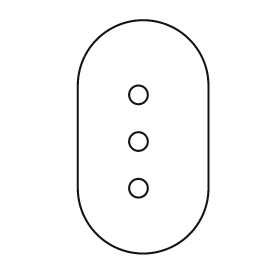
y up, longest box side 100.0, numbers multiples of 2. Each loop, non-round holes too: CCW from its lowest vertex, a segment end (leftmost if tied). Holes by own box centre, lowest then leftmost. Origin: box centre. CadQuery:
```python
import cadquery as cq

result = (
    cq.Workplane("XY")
    .moveTo(-28.0, -22.0)
    .threePointArc((0.0, -50.0), (28.0, -22.0))
    .lineTo(28.0, 22.0)
    .threePointArc((0.0, 50.0), (-28.0, 22.0))
    .close()
    .moveTo(-2.0, -22.0)
    .circle(4.0)
    .moveTo(-2.0, -2.0)
    .circle(4.0)
    .moveTo(-2.0, 18.0)
    .circle(4.0)
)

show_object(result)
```